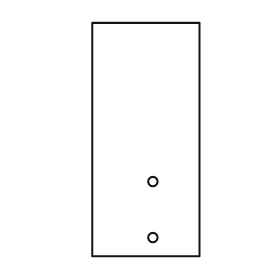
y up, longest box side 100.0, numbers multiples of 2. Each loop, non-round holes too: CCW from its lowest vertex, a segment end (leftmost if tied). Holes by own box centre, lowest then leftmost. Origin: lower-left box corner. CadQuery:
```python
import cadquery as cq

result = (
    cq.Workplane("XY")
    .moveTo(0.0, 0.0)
    .lineTo(46.0, 0.0)
    .lineTo(46.0, 100.0)
    .lineTo(0.0, 100.0)
    .close()
    .moveTo(26.0, 8.0)
    .circle(2.0)
    .moveTo(26.0, 32.0)
    .circle(2.0)
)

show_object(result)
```